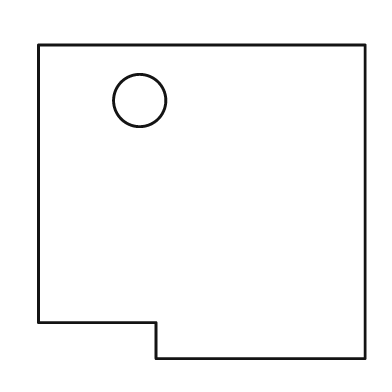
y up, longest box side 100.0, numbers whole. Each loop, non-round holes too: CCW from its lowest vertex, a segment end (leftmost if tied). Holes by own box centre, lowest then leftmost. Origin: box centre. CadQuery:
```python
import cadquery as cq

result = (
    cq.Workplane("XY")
    .moveTo(-14.0, -48.0)
    .lineTo(50.0, -48.0)
    .lineTo(50.0, 48.0)
    .lineTo(-50.0, 48.0)
    .lineTo(-50.0, -37.0)
    .lineTo(-14.0, -37.0)
    .close()
    .moveTo(-19.0, 31.0)
    .circle(8.0)
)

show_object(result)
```